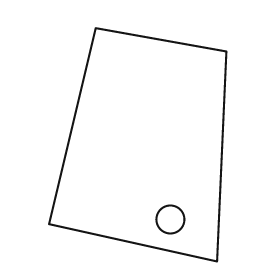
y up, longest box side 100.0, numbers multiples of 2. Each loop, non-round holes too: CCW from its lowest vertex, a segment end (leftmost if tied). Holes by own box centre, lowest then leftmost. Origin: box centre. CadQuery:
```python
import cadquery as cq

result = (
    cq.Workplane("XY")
    .moveTo(34.0, -50.0)
    .lineTo(38.0, 40.0)
    .lineTo(-18.0, 50.0)
    .lineTo(-38.0, -34.0)
    .close()
    .moveTo(14.0, -32.0)
    .circle(6.0)
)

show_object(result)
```